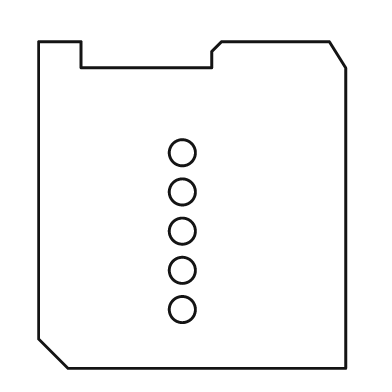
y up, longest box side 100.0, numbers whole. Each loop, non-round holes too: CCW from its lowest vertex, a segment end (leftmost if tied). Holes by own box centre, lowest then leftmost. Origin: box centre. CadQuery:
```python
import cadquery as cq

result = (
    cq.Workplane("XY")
    .moveTo(-38.0, -50.0)
    .lineTo(47.0, -50.0)
    .lineTo(47.0, 42.0)
    .lineTo(42.0, 50.0)
    .lineTo(9.0, 50.0)
    .lineTo(6.0, 47.0)
    .lineTo(6.0, 42.0)
    .lineTo(-34.0, 42.0)
    .lineTo(-34.0, 50.0)
    .lineTo(-47.0, 50.0)
    .lineTo(-47.0, -41.0)
    .close()
    .moveTo(-3.0, -32.0)
    .circle(4.0)
    .moveTo(-3.0, -20.0)
    .circle(4.0)
    .moveTo(-3.0, -8.0)
    .circle(4.0)
    .moveTo(-3.0, 4.0)
    .circle(4.0)
    .moveTo(-3.0, 16.0)
    .circle(4.0)
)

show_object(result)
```